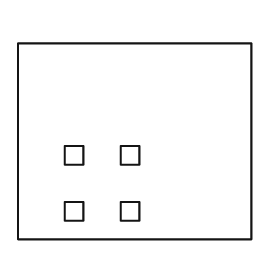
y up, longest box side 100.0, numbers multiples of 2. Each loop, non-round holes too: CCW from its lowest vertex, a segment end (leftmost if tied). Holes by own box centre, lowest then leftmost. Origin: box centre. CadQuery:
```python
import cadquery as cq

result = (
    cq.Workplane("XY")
    .moveTo(-50.0, -42.0)
    .lineTo(50.0, -42.0)
    .lineTo(50.0, 42.0)
    .lineTo(-50.0, 42.0)
    .close()
    .moveTo(-30.0, -34.0)
    .lineTo(-22.0, -34.0)
    .lineTo(-22.0, -26.0)
    .lineTo(-30.0, -26.0)
    .close()
    .moveTo(-6.0, -34.0)
    .lineTo(2.0, -34.0)
    .lineTo(2.0, -26.0)
    .lineTo(-6.0, -26.0)
    .close()
    .moveTo(-30.0, -10.0)
    .lineTo(-22.0, -10.0)
    .lineTo(-22.0, -2.0)
    .lineTo(-30.0, -2.0)
    .close()
    .moveTo(-6.0, -10.0)
    .lineTo(2.0, -10.0)
    .lineTo(2.0, -2.0)
    .lineTo(-6.0, -2.0)
    .close()
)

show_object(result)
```